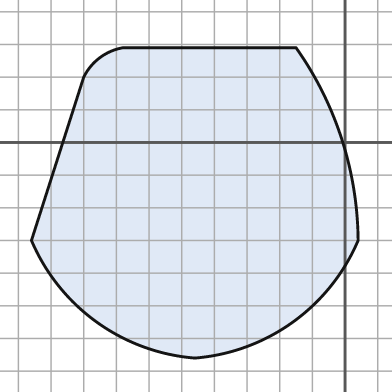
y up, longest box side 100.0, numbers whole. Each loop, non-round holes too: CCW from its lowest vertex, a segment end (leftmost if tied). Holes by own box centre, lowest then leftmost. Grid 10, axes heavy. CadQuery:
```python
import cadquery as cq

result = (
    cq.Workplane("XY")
    .moveTo(-46.0, -66.0)
    .threePointArc((-16.0, -55.0), (4.0, -30.0))
    .threePointArc((-1.0, 1.0), (-15.0, 29.0))
    .lineTo(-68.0, 29.0)
    .threePointArc((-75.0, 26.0), (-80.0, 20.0))
    .lineTo(-96.0, -30.0)
    .threePointArc((-76.0, -55.0), (-46.0, -66.0))
    .close()
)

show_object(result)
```